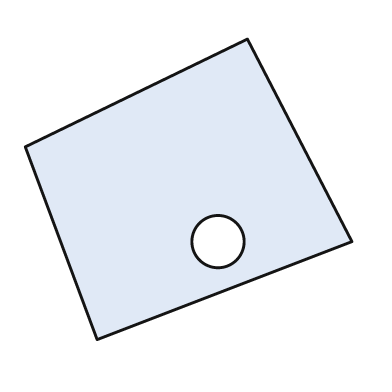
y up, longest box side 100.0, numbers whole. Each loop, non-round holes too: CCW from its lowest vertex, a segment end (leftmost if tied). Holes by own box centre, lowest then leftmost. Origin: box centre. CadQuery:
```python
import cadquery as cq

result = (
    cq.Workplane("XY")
    .moveTo(-28.0, -46.0)
    .lineTo(50.0, -16.0)
    .lineTo(18.0, 46.0)
    .lineTo(-50.0, 13.0)
    .close()
    .moveTo(9.0, -16.0)
    .circle(8.0)
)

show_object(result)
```